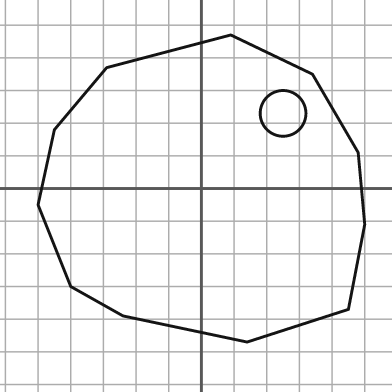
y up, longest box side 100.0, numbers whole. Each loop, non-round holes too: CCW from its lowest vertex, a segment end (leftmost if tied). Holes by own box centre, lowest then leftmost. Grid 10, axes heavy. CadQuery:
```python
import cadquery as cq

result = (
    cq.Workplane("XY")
    .moveTo(14.0, -47.0)
    .lineTo(45.0, -37.0)
    .lineTo(50.0, -11.0)
    .lineTo(48.0, 11.0)
    .lineTo(34.0, 35.0)
    .lineTo(9.0, 47.0)
    .lineTo(-29.0, 37.0)
    .lineTo(-45.0, 18.0)
    .lineTo(-50.0, -5.0)
    .lineTo(-40.0, -30.0)
    .lineTo(-24.0, -39.0)
    .close()
    .moveTo(25.0, 23.0)
    .circle(7.0)
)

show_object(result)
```